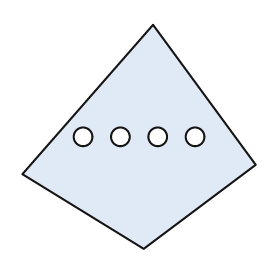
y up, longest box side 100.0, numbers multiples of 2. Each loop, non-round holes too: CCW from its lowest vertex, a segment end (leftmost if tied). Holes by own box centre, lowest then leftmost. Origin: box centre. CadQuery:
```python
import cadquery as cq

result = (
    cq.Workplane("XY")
    .moveTo(2.0, -48.0)
    .lineTo(50.0, -12.0)
    .lineTo(6.0, 48.0)
    .lineTo(-50.0, -16.0)
    .close()
    .moveTo(-24.0, 0.0)
    .circle(4.0)
    .moveTo(-8.0, 0.0)
    .circle(4.0)
    .moveTo(8.0, 0.0)
    .circle(4.0)
    .moveTo(24.0, 0.0)
    .circle(4.0)
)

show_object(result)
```